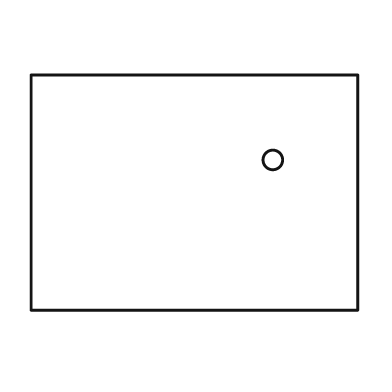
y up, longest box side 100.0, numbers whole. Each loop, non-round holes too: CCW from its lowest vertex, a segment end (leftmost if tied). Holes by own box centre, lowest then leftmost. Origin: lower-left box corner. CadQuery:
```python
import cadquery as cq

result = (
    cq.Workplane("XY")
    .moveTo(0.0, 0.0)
    .lineTo(100.0, 0.0)
    .lineTo(100.0, 72.0)
    .lineTo(0.0, 72.0)
    .close()
    .moveTo(74.0, 46.0)
    .circle(3.0)
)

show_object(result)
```